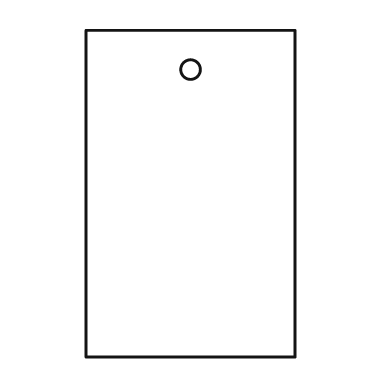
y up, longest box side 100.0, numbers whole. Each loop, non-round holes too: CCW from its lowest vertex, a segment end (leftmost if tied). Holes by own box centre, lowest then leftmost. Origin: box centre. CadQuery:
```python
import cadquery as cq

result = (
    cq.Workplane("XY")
    .moveTo(-32.0, -50.0)
    .lineTo(32.0, -50.0)
    .lineTo(32.0, 50.0)
    .lineTo(-32.0, 50.0)
    .close()
    .moveTo(0.0, 38.0)
    .circle(3.0)
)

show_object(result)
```